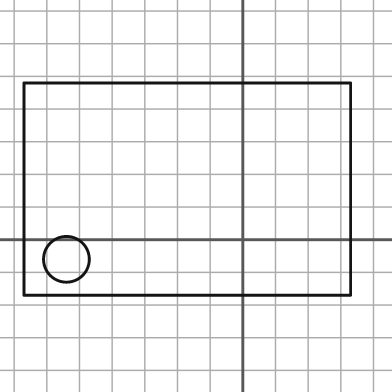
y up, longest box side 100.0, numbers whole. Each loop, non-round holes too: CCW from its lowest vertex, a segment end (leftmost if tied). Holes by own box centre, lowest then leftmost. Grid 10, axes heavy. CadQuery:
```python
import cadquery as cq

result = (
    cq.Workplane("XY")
    .moveTo(-67.0, -17.0)
    .lineTo(33.0, -17.0)
    .lineTo(33.0, 48.0)
    .lineTo(-67.0, 48.0)
    .close()
    .moveTo(-54.0, -6.0)
    .circle(7.0)
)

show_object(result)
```